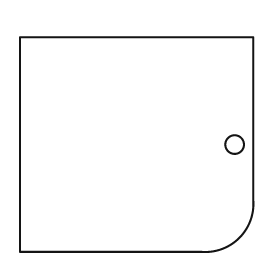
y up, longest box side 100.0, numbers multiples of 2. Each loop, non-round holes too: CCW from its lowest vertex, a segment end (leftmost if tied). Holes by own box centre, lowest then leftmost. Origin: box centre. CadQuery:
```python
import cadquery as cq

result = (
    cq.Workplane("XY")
    .moveTo(-50.0, -46.0)
    .lineTo(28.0, -46.0)
    .threePointArc((44.0, -40.0), (50.0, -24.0))
    .lineTo(50.0, 46.0)
    .lineTo(-50.0, 46.0)
    .close()
    .moveTo(42.0, 0.0)
    .circle(4.0)
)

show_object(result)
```